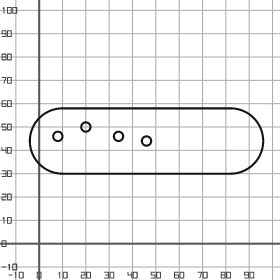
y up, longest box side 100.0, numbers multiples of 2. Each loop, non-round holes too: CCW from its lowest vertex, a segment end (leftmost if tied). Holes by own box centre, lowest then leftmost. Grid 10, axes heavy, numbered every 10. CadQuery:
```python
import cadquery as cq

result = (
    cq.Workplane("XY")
    .moveTo(10.0, 30.0)
    .lineTo(82.0, 30.0)
    .threePointArc((96.0, 44.0), (82.0, 58.0))
    .lineTo(10.0, 58.0)
    .threePointArc((-4.0, 44.0), (10.0, 30.0))
    .close()
    .moveTo(46.0, 44.0)
    .circle(2.0)
    .moveTo(8.0, 46.0)
    .circle(2.0)
    .moveTo(34.0, 46.0)
    .circle(2.0)
    .moveTo(20.0, 50.0)
    .circle(2.0)
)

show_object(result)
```